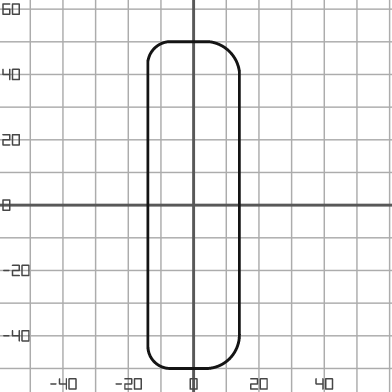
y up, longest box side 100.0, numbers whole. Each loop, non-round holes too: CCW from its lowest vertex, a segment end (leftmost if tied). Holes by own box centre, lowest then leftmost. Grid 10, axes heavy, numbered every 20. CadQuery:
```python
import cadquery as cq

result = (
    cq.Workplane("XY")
    .moveTo(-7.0, -50.0)
    .lineTo(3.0, -50.0)
    .threePointArc((11.0, -47.0), (14.0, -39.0))
    .lineTo(14.0, 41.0)
    .threePointArc((11.0, 47.0), (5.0, 50.0))
    .lineTo(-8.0, 50.0)
    .threePointArc((-12.0, 48.0), (-14.0, 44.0))
    .lineTo(-14.0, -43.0)
    .threePointArc((-12.0, -48.0), (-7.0, -50.0))
    .close()
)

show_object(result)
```